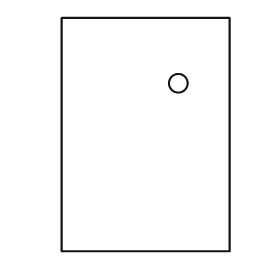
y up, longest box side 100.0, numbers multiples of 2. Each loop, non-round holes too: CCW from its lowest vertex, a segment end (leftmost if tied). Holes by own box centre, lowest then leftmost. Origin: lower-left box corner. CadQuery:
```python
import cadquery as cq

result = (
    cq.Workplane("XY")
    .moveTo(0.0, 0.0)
    .lineTo(72.0, 0.0)
    .lineTo(72.0, 100.0)
    .lineTo(0.0, 100.0)
    .close()
    .moveTo(50.0, 72.0)
    .circle(4.0)
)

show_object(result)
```